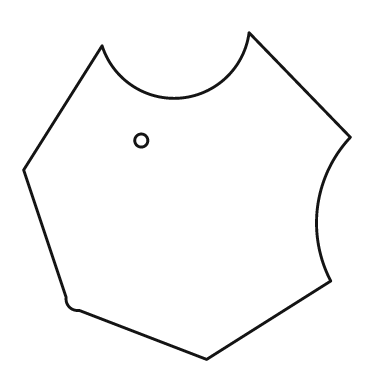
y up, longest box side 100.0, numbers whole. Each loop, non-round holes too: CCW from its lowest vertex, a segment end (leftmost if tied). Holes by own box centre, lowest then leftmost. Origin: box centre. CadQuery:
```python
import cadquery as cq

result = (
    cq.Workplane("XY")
    .moveTo(6.0, -50.0)
    .lineTo(44.0, -26.0)
    .threePointArc((40.0, -3.0), (50.0, 18.0))
    .lineTo(19.0, 50.0)
    .threePointArc((-2.0, 30.0), (-26.0, 46.0))
    .lineTo(-50.0, 8.0)
    .lineTo(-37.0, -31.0)
    .threePointArc((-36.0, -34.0), (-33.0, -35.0))
    .close()
    .moveTo(-14.0, 17.0)
    .circle(2.0)
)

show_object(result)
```